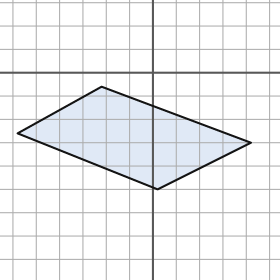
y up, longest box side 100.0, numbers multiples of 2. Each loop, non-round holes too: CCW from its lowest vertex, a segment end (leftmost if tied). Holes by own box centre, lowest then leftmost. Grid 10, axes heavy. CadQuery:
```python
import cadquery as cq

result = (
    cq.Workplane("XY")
    .moveTo(2.0, -50.0)
    .lineTo(42.0, -30.0)
    .lineTo(-22.0, -6.0)
    .lineTo(-58.0, -26.0)
    .close()
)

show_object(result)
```